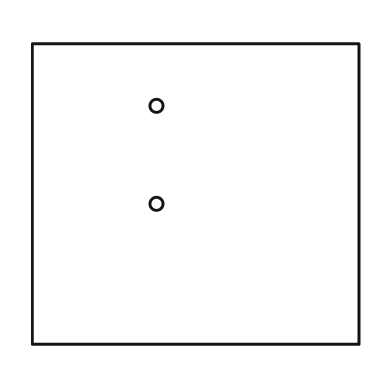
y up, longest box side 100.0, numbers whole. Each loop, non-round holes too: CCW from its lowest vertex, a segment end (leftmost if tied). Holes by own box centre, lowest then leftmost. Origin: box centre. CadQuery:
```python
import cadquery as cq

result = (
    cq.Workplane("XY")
    .moveTo(-50.0, -46.0)
    .lineTo(50.0, -46.0)
    .lineTo(50.0, 46.0)
    .lineTo(-50.0, 46.0)
    .close()
    .moveTo(-12.0, -3.0)
    .circle(2.0)
    .moveTo(-12.0, 27.0)
    .circle(2.0)
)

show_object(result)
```